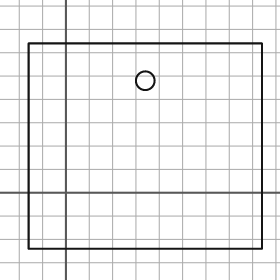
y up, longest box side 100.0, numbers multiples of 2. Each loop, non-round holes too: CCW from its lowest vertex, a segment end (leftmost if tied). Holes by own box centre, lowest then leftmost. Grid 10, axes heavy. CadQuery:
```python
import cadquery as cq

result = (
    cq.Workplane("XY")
    .moveTo(-16.0, -24.0)
    .lineTo(84.0, -24.0)
    .lineTo(84.0, 64.0)
    .lineTo(-16.0, 64.0)
    .close()
    .moveTo(34.0, 48.0)
    .circle(4.0)
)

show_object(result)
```